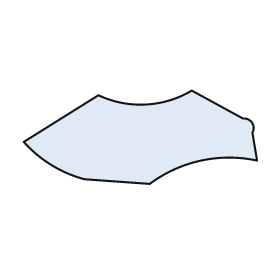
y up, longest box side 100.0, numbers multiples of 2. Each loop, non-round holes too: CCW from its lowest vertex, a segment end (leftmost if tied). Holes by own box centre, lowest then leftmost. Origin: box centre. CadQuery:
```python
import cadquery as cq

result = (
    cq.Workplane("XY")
    .moveTo(4.0, -20.0)
    .threePointArc((26.0, -10.0), (50.0, -10.0))
    .lineTo(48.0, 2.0)
    .threePointArc((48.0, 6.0), (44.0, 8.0))
    .lineTo(22.0, 20.0)
    .threePointArc((2.0, 14.0), (-18.0, 18.0))
    .lineTo(-50.0, -2.0)
    .threePointArc((-38.0, -12.0), (-24.0, -18.0))
    .close()
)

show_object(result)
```